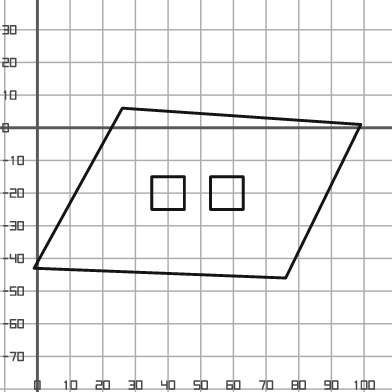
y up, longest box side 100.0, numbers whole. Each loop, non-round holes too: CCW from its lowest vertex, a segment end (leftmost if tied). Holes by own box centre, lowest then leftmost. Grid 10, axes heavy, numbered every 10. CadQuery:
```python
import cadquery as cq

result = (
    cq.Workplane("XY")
    .moveTo(76.0, -46.0)
    .lineTo(99.0, 1.0)
    .lineTo(26.0, 6.0)
    .lineTo(-1.0, -43.0)
    .close()
    .moveTo(35.0, -25.0)
    .lineTo(45.0, -25.0)
    .lineTo(45.0, -15.0)
    .lineTo(35.0, -15.0)
    .close()
    .moveTo(53.0, -25.0)
    .lineTo(63.0, -25.0)
    .lineTo(63.0, -15.0)
    .lineTo(53.0, -15.0)
    .close()
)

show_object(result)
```